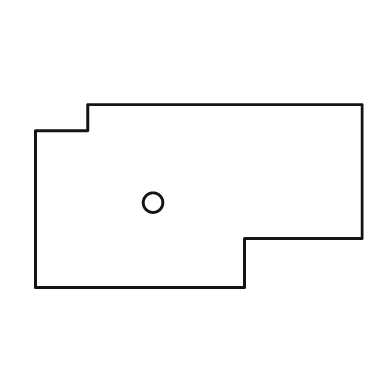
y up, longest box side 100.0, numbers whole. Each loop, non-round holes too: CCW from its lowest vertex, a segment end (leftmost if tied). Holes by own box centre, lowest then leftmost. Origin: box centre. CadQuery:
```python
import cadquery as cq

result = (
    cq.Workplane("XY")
    .moveTo(-50.0, -28.0)
    .lineTo(14.0, -28.0)
    .lineTo(14.0, -13.0)
    .lineTo(50.0, -13.0)
    .lineTo(50.0, 28.0)
    .lineTo(-34.0, 28.0)
    .lineTo(-34.0, 20.0)
    .lineTo(-50.0, 20.0)
    .close()
    .moveTo(-14.0, -2.0)
    .circle(3.0)
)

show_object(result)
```